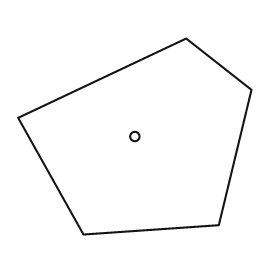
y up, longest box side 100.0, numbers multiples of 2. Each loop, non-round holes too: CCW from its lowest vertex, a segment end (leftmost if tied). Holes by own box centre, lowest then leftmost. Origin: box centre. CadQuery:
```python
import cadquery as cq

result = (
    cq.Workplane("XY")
    .moveTo(-22.0, -42.0)
    .lineTo(36.0, -38.0)
    .lineTo(50.0, 20.0)
    .lineTo(22.0, 42.0)
    .lineTo(-50.0, 8.0)
    .close()
    .moveTo(0.0, 0.0)
    .circle(2.0)
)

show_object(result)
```